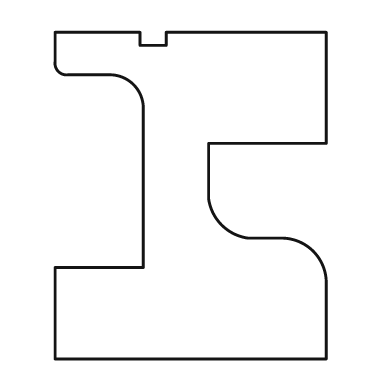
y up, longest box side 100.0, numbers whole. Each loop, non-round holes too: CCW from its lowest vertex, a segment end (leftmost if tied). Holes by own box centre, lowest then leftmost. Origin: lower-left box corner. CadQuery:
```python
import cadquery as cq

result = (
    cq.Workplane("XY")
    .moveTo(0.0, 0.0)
    .lineTo(83.0, 0.0)
    .lineTo(83.0, 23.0)
    .threePointArc((79.0, 33.0), (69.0, 37.0))
    .lineTo(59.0, 37.0)
    .threePointArc((51.0, 41.0), (47.0, 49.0))
    .lineTo(47.0, 66.0)
    .lineTo(83.0, 66.0)
    .lineTo(83.0, 100.0)
    .lineTo(34.0, 100.0)
    .lineTo(34.0, 96.0)
    .lineTo(26.0, 96.0)
    .lineTo(26.0, 100.0)
    .lineTo(0.0, 100.0)
    .lineTo(0.0, 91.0)
    .threePointArc((1.0, 88.0), (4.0, 87.0))
    .lineTo(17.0, 87.0)
    .threePointArc((24.0, 84.0), (27.0, 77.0))
    .lineTo(27.0, 28.0)
    .lineTo(0.0, 28.0)
    .close()
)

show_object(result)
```